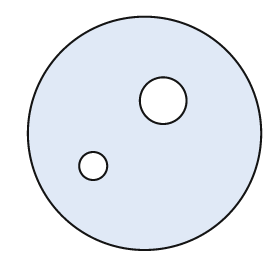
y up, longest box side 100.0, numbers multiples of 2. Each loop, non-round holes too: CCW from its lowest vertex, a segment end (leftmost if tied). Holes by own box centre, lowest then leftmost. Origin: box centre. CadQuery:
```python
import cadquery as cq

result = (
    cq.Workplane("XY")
    .moveTo(0.0, 0.0)
    .circle(50.0)
    .moveTo(-22.0, -14.0)
    .circle(6.0)
    .moveTo(8.0, 14.0)
    .circle(10.0)
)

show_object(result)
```